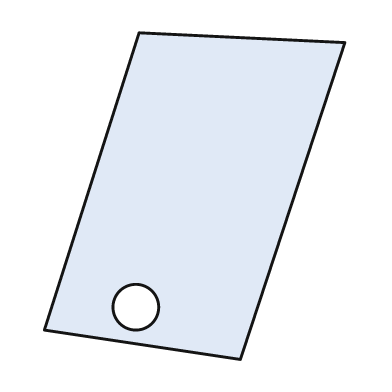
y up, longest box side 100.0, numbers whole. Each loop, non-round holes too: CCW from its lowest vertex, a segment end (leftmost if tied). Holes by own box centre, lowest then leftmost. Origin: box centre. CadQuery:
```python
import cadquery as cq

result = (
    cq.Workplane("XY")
    .moveTo(14.0, -50.0)
    .lineTo(46.0, 47.0)
    .lineTo(-17.0, 50.0)
    .lineTo(-46.0, -41.0)
    .close()
    .moveTo(-18.0, -34.0)
    .circle(7.0)
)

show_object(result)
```